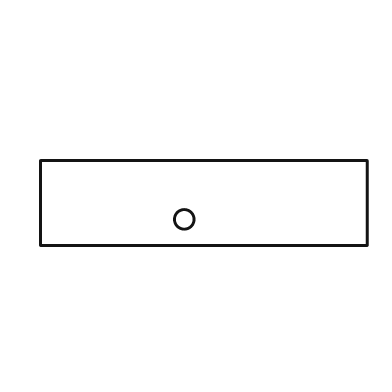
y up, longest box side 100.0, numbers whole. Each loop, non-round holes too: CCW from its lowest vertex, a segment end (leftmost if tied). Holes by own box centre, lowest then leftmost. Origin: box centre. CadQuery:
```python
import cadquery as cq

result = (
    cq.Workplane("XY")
    .moveTo(-50.0, -13.0)
    .lineTo(50.0, -13.0)
    .lineTo(50.0, 13.0)
    .lineTo(-50.0, 13.0)
    .close()
    .moveTo(-6.0, -5.0)
    .circle(3.0)
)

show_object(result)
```